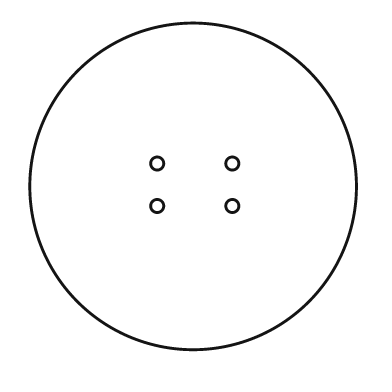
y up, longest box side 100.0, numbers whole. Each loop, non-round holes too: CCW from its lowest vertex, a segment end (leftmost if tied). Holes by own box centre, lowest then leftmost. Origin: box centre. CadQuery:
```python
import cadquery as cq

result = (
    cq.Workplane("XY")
    .moveTo(0.0, 0.0)
    .circle(50.0)
    .moveTo(-11.0, -6.0)
    .circle(2.0)
    .moveTo(12.0, -6.0)
    .circle(2.0)
    .moveTo(-11.0, 7.0)
    .circle(2.0)
    .moveTo(12.0, 7.0)
    .circle(2.0)
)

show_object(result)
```